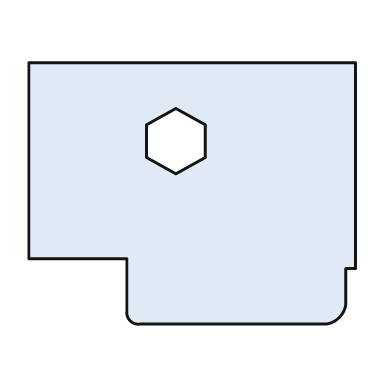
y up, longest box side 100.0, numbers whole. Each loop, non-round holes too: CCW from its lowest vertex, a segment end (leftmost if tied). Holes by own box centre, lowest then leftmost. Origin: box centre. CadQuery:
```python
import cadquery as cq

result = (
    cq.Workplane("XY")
    .moveTo(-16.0, -40.0)
    .lineTo(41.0, -40.0)
    .threePointArc((45.0, -38.0), (47.0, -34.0))
    .lineTo(47.0, -23.0)
    .lineTo(50.0, -23.0)
    .lineTo(50.0, 40.0)
    .lineTo(-50.0, 40.0)
    .lineTo(-50.0, -20.0)
    .lineTo(-20.0, -20.0)
    .lineTo(-20.0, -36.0)
    .threePointArc((-19.0, -39.0), (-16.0, -40.0))
    .close()
    .moveTo(-5.0, 6.0)
    .lineTo(4.0, 11.0)
    .lineTo(4.0, 21.0)
    .lineTo(-5.0, 26.0)
    .lineTo(-14.0, 21.0)
    .lineTo(-14.0, 11.0)
    .close()
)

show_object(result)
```